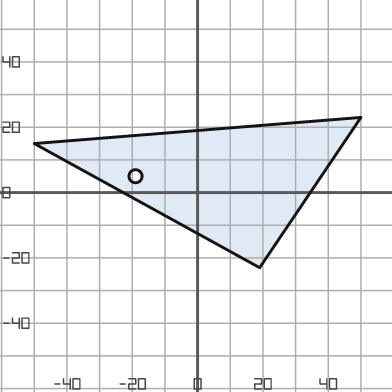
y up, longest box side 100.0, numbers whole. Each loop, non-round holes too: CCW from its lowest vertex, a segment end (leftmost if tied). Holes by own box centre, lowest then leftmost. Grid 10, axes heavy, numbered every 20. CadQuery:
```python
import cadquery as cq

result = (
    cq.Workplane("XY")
    .moveTo(19.0, -23.0)
    .lineTo(50.0, 23.0)
    .lineTo(-50.0, 15.0)
    .close()
    .moveTo(-19.0, 5.0)
    .circle(2.0)
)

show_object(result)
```